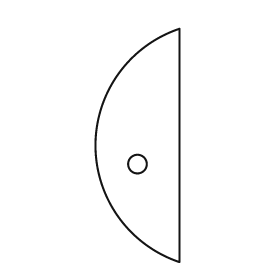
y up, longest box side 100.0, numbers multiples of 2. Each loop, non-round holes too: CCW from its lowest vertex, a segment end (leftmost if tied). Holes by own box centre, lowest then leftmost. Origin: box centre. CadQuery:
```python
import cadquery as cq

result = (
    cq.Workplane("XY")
    .moveTo(18.0, -50.0)
    .lineTo(18.0, 50.0)
    .threePointArc((-18.0, 0.0), (18.0, -50.0))
    .close()
    .moveTo(0.0, -8.0)
    .circle(4.0)
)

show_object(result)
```